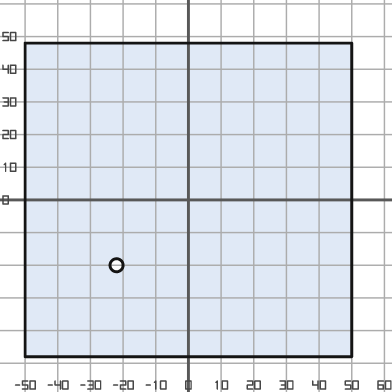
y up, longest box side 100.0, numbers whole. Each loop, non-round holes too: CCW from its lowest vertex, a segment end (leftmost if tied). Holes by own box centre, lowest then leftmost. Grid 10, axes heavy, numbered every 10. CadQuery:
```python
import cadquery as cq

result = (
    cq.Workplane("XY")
    .moveTo(-50.0, -48.0)
    .lineTo(50.0, -48.0)
    .lineTo(50.0, 48.0)
    .lineTo(-50.0, 48.0)
    .close()
    .moveTo(-22.0, -20.0)
    .circle(2.0)
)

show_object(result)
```